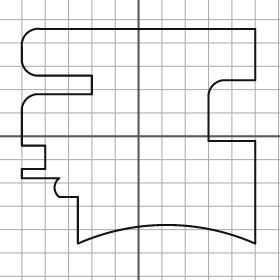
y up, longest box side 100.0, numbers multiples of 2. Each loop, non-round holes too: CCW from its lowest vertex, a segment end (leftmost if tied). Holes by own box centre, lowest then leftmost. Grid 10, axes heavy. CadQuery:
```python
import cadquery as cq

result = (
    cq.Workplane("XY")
    .moveTo(-26.0, -46.0)
    .threePointArc((12.0, -38.0), (50.0, -46.0))
    .lineTo(50.0, -2.0)
    .lineTo(30.0, -2.0)
    .lineTo(30.0, 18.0)
    .threePointArc((32.0, 22.0), (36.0, 24.0))
    .lineTo(50.0, 24.0)
    .lineTo(50.0, 46.0)
    .lineTo(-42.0, 46.0)
    .threePointArc((-48.0, 44.0), (-50.0, 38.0))
    .lineTo(-50.0, 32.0)
    .threePointArc((-48.0, 28.0), (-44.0, 26.0))
    .lineTo(-20.0, 26.0)
    .lineTo(-20.0, 18.0)
    .lineTo(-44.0, 18.0)
    .threePointArc((-48.0, 16.0), (-50.0, 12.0))
    .lineTo(-50.0, -4.0)
    .lineTo(-40.0, -4.0)
    .lineTo(-40.0, -14.0)
    .lineTo(-50.0, -14.0)
    .lineTo(-50.0, -18.0)
    .lineTo(-34.0, -18.0)
    .threePointArc((-36.0, -22.0), (-34.0, -26.0))
    .lineTo(-26.0, -26.0)
    .close()
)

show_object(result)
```